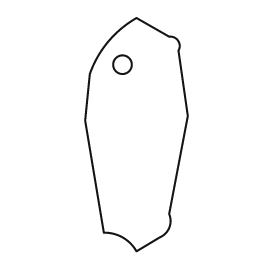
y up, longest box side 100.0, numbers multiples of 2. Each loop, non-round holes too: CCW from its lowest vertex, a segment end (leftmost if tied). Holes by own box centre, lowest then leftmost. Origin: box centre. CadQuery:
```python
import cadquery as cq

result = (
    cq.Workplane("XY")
    .moveTo(0.0, -50.0)
    .lineTo(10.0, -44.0)
    .threePointArc((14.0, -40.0), (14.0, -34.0))
    .lineTo(22.0, 8.0)
    .lineTo(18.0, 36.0)
    .threePointArc((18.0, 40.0), (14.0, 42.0))
    .lineTo(0.0, 50.0)
    .threePointArc((-12.0, 40.0), (-20.0, 26.0))
    .lineTo(-22.0, 6.0)
    .lineTo(-14.0, -42.0)
    .threePointArc((-6.0, -44.0), (0.0, -50.0))
    .close()
    .moveTo(-6.0, 30.0)
    .circle(4.0)
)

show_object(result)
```